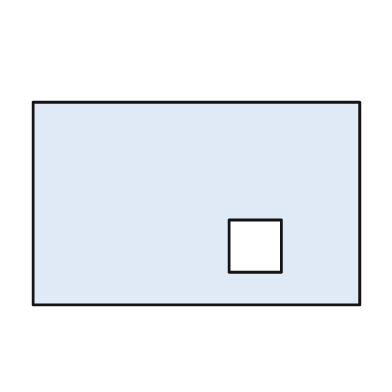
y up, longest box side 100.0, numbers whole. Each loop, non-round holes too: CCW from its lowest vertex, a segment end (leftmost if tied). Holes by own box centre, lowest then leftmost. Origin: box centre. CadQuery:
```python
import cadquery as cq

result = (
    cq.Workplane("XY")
    .moveTo(-50.0, -31.0)
    .lineTo(50.0, -31.0)
    .lineTo(50.0, 31.0)
    .lineTo(-50.0, 31.0)
    .close()
    .moveTo(10.0, -21.0)
    .lineTo(26.0, -21.0)
    .lineTo(26.0, -5.0)
    .lineTo(10.0, -5.0)
    .close()
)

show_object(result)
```